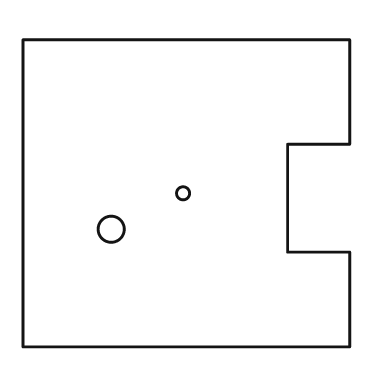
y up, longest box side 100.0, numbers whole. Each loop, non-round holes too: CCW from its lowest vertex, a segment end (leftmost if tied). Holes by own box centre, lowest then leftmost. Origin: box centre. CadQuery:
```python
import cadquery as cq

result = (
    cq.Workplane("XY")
    .moveTo(-50.0, -47.0)
    .lineTo(50.0, -47.0)
    .lineTo(50.0, -18.0)
    .lineTo(31.0, -18.0)
    .lineTo(31.0, 15.0)
    .lineTo(50.0, 15.0)
    .lineTo(50.0, 47.0)
    .lineTo(-50.0, 47.0)
    .close()
    .moveTo(-23.0, -11.0)
    .circle(4.0)
    .moveTo(-1.0, 0.0)
    .circle(2.0)
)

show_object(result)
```